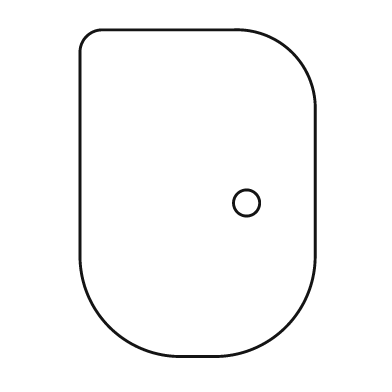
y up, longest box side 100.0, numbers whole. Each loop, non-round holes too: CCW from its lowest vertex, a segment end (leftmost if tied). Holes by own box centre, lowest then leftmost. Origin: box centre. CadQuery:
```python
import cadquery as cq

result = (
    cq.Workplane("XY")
    .moveTo(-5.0, -50.0)
    .lineTo(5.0, -50.0)
    .threePointArc((27.0, -41.0), (36.0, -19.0))
    .lineTo(36.0, 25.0)
    .threePointArc((29.0, 43.0), (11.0, 50.0))
    .lineTo(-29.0, 50.0)
    .threePointArc((-34.0, 48.0), (-36.0, 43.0))
    .lineTo(-36.0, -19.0)
    .threePointArc((-27.0, -41.0), (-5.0, -50.0))
    .close()
    .moveTo(15.0, -3.0)
    .circle(4.0)
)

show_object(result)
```